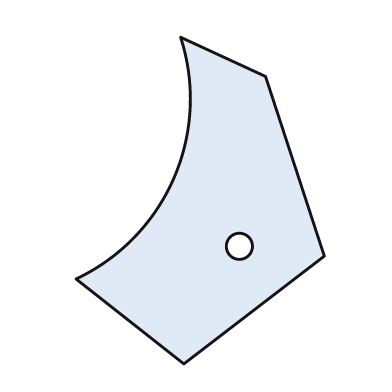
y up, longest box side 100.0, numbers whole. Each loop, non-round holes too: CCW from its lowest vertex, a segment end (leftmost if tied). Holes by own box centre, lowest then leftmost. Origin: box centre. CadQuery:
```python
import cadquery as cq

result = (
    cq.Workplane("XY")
    .moveTo(-5.0, -50.0)
    .lineTo(38.0, -17.0)
    .lineTo(20.0, 38.0)
    .lineTo(-6.0, 50.0)
    .threePointArc((-8.0, 7.0), (-38.0, -24.0))
    .close()
    .moveTo(12.0, -14.0)
    .circle(4.0)
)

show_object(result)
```